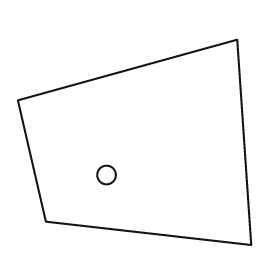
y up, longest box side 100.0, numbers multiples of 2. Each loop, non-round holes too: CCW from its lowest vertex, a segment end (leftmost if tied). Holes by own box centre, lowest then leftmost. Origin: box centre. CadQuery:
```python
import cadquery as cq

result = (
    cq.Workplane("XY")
    .moveTo(50.0, -44.0)
    .lineTo(44.0, 44.0)
    .lineTo(-50.0, 18.0)
    .lineTo(-38.0, -34.0)
    .close()
    .moveTo(-12.0, -14.0)
    .circle(4.0)
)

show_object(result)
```